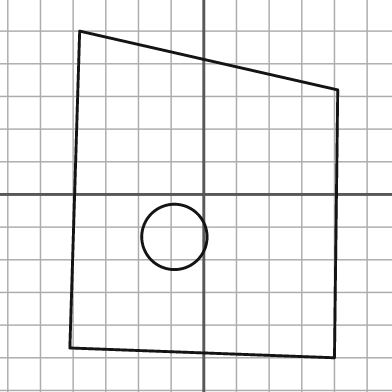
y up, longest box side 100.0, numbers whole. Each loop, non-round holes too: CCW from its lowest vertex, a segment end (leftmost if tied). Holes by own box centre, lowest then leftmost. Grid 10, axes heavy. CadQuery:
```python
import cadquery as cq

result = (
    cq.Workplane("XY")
    .moveTo(40.0, -50.0)
    .lineTo(41.0, 32.0)
    .lineTo(-38.0, 50.0)
    .lineTo(-41.0, -47.0)
    .close()
    .moveTo(-9.0, -13.0)
    .circle(10.0)
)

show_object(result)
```